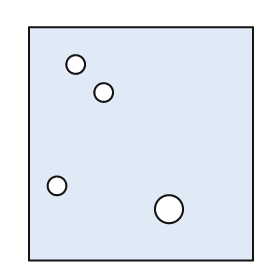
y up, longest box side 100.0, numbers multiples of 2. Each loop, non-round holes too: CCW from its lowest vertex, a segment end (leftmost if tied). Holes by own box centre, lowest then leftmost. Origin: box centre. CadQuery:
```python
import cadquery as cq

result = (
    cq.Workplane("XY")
    .moveTo(-48.0, -50.0)
    .lineTo(48.0, -50.0)
    .lineTo(48.0, 50.0)
    .lineTo(-48.0, 50.0)
    .close()
    .moveTo(12.0, -28.0)
    .circle(6.0)
    .moveTo(-36.0, -18.0)
    .circle(4.0)
    .moveTo(-16.0, 22.0)
    .circle(4.0)
    .moveTo(-28.0, 34.0)
    .circle(4.0)
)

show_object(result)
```